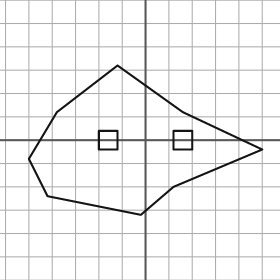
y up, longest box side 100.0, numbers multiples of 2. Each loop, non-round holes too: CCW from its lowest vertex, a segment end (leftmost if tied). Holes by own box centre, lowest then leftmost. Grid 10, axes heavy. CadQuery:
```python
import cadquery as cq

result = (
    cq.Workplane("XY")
    .moveTo(-2.0, -32.0)
    .lineTo(12.0, -20.0)
    .lineTo(50.0, -4.0)
    .lineTo(16.0, 12.0)
    .lineTo(-12.0, 32.0)
    .lineTo(-38.0, 12.0)
    .lineTo(-50.0, -8.0)
    .lineTo(-42.0, -24.0)
    .close()
    .moveTo(-20.0, -4.0)
    .lineTo(-12.0, -4.0)
    .lineTo(-12.0, 4.0)
    .lineTo(-20.0, 4.0)
    .close()
    .moveTo(12.0, -4.0)
    .lineTo(20.0, -4.0)
    .lineTo(20.0, 4.0)
    .lineTo(12.0, 4.0)
    .close()
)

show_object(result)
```